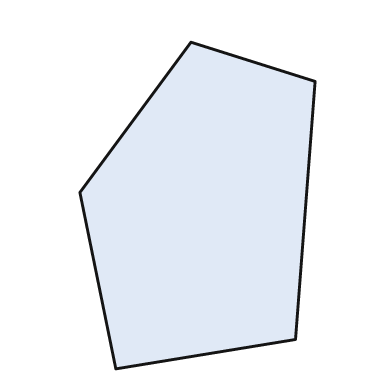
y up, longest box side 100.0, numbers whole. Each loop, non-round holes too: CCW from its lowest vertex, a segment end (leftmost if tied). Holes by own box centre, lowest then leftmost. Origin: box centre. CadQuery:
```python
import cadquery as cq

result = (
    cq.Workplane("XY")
    .moveTo(-25.0, -50.0)
    .lineTo(30.0, -41.0)
    .lineTo(36.0, 38.0)
    .lineTo(-2.0, 50.0)
    .lineTo(-36.0, 4.0)
    .close()
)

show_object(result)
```